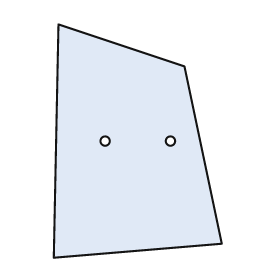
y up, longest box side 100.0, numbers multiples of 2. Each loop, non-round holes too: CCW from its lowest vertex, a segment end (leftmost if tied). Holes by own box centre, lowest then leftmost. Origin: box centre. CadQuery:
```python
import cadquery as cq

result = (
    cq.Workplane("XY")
    .moveTo(-36.0, -50.0)
    .lineTo(36.0, -44.0)
    .lineTo(20.0, 32.0)
    .lineTo(-34.0, 50.0)
    .close()
    .moveTo(-14.0, 0.0)
    .circle(2.0)
    .moveTo(14.0, 0.0)
    .circle(2.0)
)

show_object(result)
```